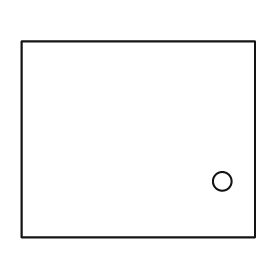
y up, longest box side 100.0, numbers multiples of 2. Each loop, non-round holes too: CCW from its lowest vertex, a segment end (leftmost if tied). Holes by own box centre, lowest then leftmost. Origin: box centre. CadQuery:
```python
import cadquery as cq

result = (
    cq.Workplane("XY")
    .moveTo(-50.0, -42.0)
    .lineTo(50.0, -42.0)
    .lineTo(50.0, 42.0)
    .lineTo(-50.0, 42.0)
    .close()
    .moveTo(36.0, -18.0)
    .circle(4.0)
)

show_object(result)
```